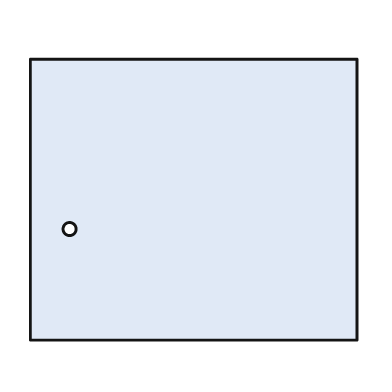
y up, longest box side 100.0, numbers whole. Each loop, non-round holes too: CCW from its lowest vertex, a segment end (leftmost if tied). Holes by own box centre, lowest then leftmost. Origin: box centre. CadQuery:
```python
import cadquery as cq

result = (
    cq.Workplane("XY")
    .moveTo(-50.0, -43.0)
    .lineTo(50.0, -43.0)
    .lineTo(50.0, 43.0)
    .lineTo(-50.0, 43.0)
    .close()
    .moveTo(-38.0, -9.0)
    .circle(2.0)
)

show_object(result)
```